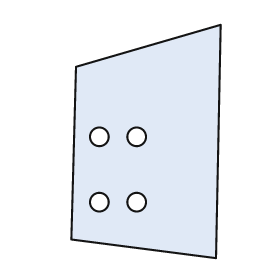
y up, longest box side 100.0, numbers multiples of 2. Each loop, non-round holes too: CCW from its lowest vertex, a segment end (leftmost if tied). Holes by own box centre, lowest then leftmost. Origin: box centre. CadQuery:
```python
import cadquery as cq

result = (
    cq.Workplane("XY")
    .moveTo(30.0, -50.0)
    .lineTo(32.0, 50.0)
    .lineTo(-30.0, 32.0)
    .lineTo(-32.0, -42.0)
    .close()
    .moveTo(-20.0, -26.0)
    .circle(4.0)
    .moveTo(-4.0, -26.0)
    .circle(4.0)
    .moveTo(-20.0, 2.0)
    .circle(4.0)
    .moveTo(-4.0, 2.0)
    .circle(4.0)
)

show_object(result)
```